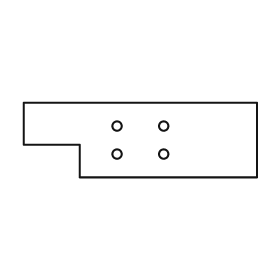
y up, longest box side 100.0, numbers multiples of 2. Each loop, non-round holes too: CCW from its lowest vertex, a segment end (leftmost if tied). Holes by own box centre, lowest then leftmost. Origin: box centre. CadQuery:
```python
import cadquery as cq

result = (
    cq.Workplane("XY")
    .moveTo(-26.0, -16.0)
    .lineTo(50.0, -16.0)
    .lineTo(50.0, 16.0)
    .lineTo(-50.0, 16.0)
    .lineTo(-50.0, -2.0)
    .lineTo(-26.0, -2.0)
    .close()
    .moveTo(-10.0, -6.0)
    .circle(2.0)
    .moveTo(10.0, -6.0)
    .circle(2.0)
    .moveTo(-10.0, 6.0)
    .circle(2.0)
    .moveTo(10.0, 6.0)
    .circle(2.0)
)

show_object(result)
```